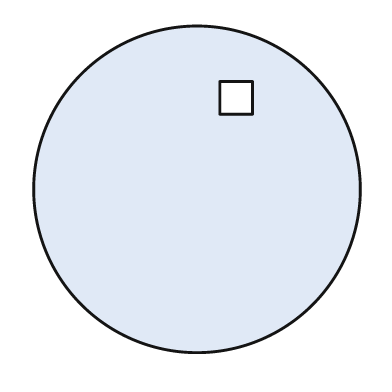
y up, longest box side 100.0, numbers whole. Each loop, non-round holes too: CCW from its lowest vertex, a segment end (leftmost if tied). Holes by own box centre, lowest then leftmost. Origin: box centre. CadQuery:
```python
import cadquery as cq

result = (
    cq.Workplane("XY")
    .moveTo(0.0, 0.0)
    .circle(50.0)
    .moveTo(7.0, 23.0)
    .lineTo(17.0, 23.0)
    .lineTo(17.0, 33.0)
    .lineTo(7.0, 33.0)
    .close()
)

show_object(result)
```